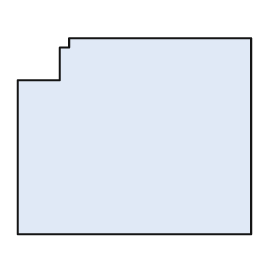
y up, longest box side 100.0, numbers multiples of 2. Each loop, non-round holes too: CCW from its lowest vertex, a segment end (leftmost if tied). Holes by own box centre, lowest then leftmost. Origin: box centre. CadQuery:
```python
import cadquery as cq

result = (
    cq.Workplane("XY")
    .moveTo(-50.0, -42.0)
    .lineTo(50.0, -42.0)
    .lineTo(50.0, 42.0)
    .lineTo(-28.0, 42.0)
    .lineTo(-28.0, 38.0)
    .lineTo(-32.0, 38.0)
    .lineTo(-32.0, 24.0)
    .lineTo(-50.0, 24.0)
    .close()
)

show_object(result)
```